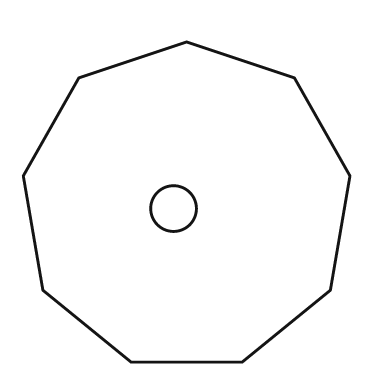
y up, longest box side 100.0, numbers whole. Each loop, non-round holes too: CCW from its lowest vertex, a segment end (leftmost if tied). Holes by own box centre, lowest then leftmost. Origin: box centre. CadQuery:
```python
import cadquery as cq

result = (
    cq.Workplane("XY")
    .moveTo(-17.0, -49.0)
    .lineTo(17.0, -49.0)
    .lineTo(44.0, -27.0)
    .lineTo(50.0, 8.0)
    .lineTo(33.0, 38.0)
    .lineTo(0.0, 49.0)
    .lineTo(-33.0, 38.0)
    .lineTo(-50.0, 8.0)
    .lineTo(-44.0, -27.0)
    .close()
    .moveTo(-4.0, -2.0)
    .circle(7.0)
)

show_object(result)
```